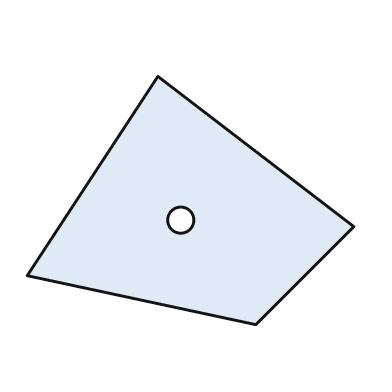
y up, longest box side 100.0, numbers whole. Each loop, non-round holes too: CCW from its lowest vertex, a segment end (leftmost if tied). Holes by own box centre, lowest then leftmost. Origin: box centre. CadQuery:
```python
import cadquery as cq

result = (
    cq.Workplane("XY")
    .moveTo(20.0, -38.0)
    .lineTo(50.0, -8.0)
    .lineTo(-10.0, 38.0)
    .lineTo(-50.0, -23.0)
    .close()
    .moveTo(-3.0, -6.0)
    .circle(4.0)
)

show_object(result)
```